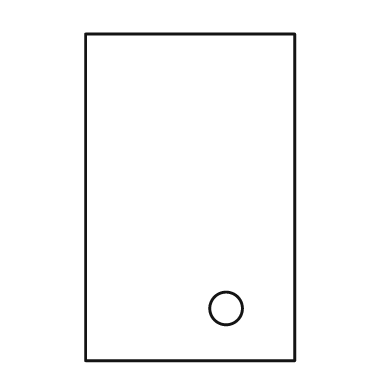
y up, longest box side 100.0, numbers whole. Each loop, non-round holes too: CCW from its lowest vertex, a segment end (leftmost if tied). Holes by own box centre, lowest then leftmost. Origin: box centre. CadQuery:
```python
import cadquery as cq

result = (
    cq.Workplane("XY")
    .moveTo(-32.0, -50.0)
    .lineTo(32.0, -50.0)
    .lineTo(32.0, 50.0)
    .lineTo(-32.0, 50.0)
    .close()
    .moveTo(11.0, -34.0)
    .circle(5.0)
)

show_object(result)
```